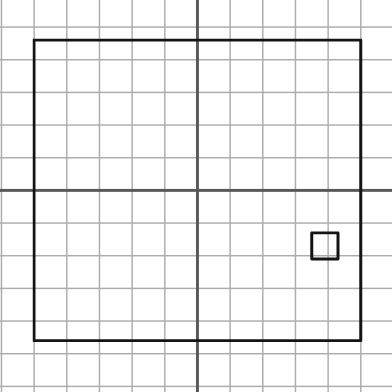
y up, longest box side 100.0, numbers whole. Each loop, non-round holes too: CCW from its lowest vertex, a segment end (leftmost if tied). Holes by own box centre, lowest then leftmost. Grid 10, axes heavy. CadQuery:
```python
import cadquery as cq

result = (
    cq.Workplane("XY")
    .moveTo(-50.0, -46.0)
    .lineTo(50.0, -46.0)
    .lineTo(50.0, 46.0)
    .lineTo(-50.0, 46.0)
    .close()
    .moveTo(35.0, -21.0)
    .lineTo(43.0, -21.0)
    .lineTo(43.0, -13.0)
    .lineTo(35.0, -13.0)
    .close()
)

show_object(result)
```